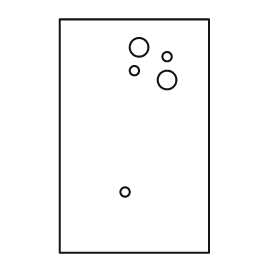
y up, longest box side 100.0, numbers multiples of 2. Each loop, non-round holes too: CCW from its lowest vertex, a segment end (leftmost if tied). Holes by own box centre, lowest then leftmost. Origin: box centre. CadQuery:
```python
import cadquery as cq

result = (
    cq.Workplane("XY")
    .moveTo(-32.0, -50.0)
    .lineTo(32.0, -50.0)
    .lineTo(32.0, 50.0)
    .lineTo(-32.0, 50.0)
    .close()
    .moveTo(-4.0, -24.0)
    .circle(2.0)
    .moveTo(14.0, 24.0)
    .circle(4.0)
    .moveTo(0.0, 28.0)
    .circle(2.0)
    .moveTo(14.0, 34.0)
    .circle(2.0)
    .moveTo(2.0, 38.0)
    .circle(4.0)
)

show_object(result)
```